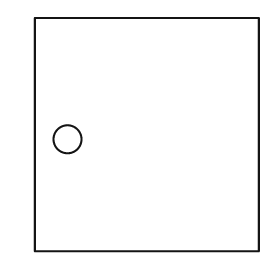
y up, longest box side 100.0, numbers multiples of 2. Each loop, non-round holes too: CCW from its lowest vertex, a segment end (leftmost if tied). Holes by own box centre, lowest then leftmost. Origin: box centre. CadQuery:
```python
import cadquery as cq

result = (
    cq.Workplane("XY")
    .moveTo(-48.0, -50.0)
    .lineTo(48.0, -50.0)
    .lineTo(48.0, 50.0)
    .lineTo(-48.0, 50.0)
    .close()
    .moveTo(-34.0, -2.0)
    .circle(6.0)
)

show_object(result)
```